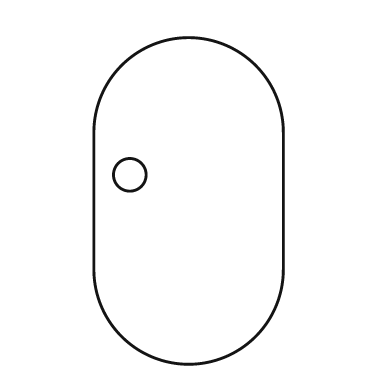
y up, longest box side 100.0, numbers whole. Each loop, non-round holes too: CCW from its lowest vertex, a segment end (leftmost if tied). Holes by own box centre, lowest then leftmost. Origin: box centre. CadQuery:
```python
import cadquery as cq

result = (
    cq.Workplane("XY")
    .moveTo(-29.0, -21.0)
    .threePointArc((0.0, -50.0), (29.0, -21.0))
    .lineTo(29.0, 21.0)
    .threePointArc((0.0, 50.0), (-29.0, 21.0))
    .close()
    .moveTo(-18.0, 8.0)
    .circle(5.0)
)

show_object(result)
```